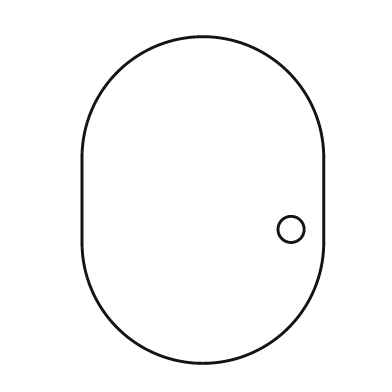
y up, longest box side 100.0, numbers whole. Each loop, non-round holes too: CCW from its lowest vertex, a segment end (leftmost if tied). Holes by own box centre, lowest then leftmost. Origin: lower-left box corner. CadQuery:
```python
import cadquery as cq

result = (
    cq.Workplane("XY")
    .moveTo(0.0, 37.0)
    .threePointArc((37.0, 0.0), (74.0, 37.0))
    .lineTo(74.0, 63.0)
    .threePointArc((37.0, 100.0), (0.0, 63.0))
    .close()
    .moveTo(64.0, 41.0)
    .circle(4.0)
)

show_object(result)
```